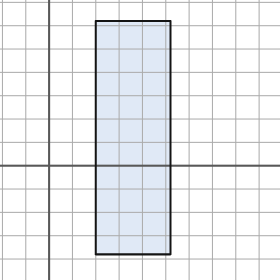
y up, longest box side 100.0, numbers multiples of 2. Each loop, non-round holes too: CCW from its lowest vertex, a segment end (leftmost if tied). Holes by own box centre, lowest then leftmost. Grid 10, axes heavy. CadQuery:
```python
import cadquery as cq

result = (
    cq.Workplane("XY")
    .moveTo(20.0, -38.0)
    .lineTo(52.0, -38.0)
    .lineTo(52.0, 62.0)
    .lineTo(20.0, 62.0)
    .close()
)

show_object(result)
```